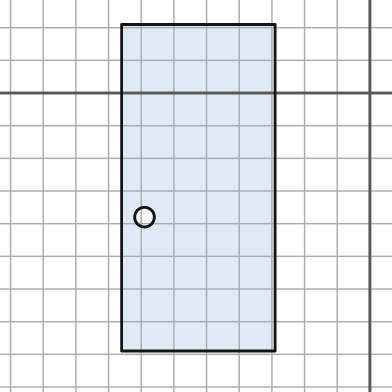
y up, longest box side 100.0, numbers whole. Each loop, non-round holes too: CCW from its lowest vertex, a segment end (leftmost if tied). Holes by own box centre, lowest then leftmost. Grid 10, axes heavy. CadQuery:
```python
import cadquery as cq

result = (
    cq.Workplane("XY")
    .moveTo(-76.0, -79.0)
    .lineTo(-29.0, -79.0)
    .lineTo(-29.0, 21.0)
    .lineTo(-76.0, 21.0)
    .close()
    .moveTo(-69.0, -38.0)
    .circle(3.0)
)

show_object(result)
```